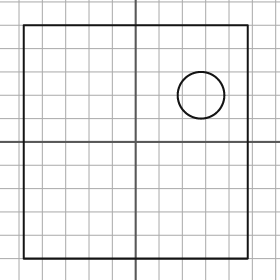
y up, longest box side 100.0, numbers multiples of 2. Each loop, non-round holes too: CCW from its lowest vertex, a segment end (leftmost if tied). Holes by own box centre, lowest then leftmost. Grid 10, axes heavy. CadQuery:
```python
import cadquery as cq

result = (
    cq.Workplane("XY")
    .moveTo(-48.0, -50.0)
    .lineTo(48.0, -50.0)
    .lineTo(48.0, 50.0)
    .lineTo(-48.0, 50.0)
    .close()
    .moveTo(28.0, 20.0)
    .circle(10.0)
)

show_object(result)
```